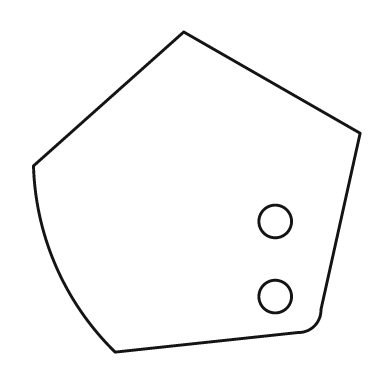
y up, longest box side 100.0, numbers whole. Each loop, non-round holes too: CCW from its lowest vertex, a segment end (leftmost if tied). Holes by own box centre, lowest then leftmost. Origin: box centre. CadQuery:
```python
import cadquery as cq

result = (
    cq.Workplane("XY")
    .moveTo(-25.0, -49.0)
    .lineTo(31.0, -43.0)
    .threePointArc((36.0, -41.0), (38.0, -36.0))
    .lineTo(50.0, 18.0)
    .lineTo(-4.0, 49.0)
    .lineTo(-50.0, 8.0)
    .threePointArc((-43.0, -23.0), (-25.0, -49.0))
    .close()
    .moveTo(24.0, -32.0)
    .circle(5.0)
    .moveTo(24.0, -9.0)
    .circle(5.0)
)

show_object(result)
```